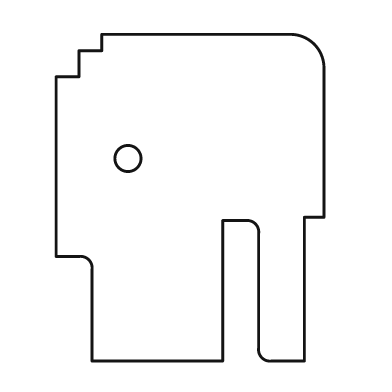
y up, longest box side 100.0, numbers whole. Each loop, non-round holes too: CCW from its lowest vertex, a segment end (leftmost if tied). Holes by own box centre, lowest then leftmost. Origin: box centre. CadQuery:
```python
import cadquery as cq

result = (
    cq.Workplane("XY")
    .moveTo(-30.0, -50.0)
    .lineTo(10.0, -50.0)
    .lineTo(10.0, -7.0)
    .lineTo(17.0, -7.0)
    .threePointArc((20.0, -8.0), (21.0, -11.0))
    .lineTo(21.0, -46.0)
    .threePointArc((22.0, -49.0), (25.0, -50.0))
    .lineTo(35.0, -50.0)
    .lineTo(35.0, -6.0)
    .lineTo(41.0, -6.0)
    .lineTo(41.0, 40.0)
    .threePointArc((38.0, 47.0), (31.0, 50.0))
    .lineTo(-27.0, 50.0)
    .lineTo(-27.0, 45.0)
    .lineTo(-34.0, 45.0)
    .lineTo(-34.0, 37.0)
    .lineTo(-41.0, 37.0)
    .lineTo(-41.0, -18.0)
    .lineTo(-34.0, -18.0)
    .threePointArc((-31.0, -19.0), (-30.0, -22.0))
    .close()
    .moveTo(-19.0, 12.0)
    .circle(4.0)
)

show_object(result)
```